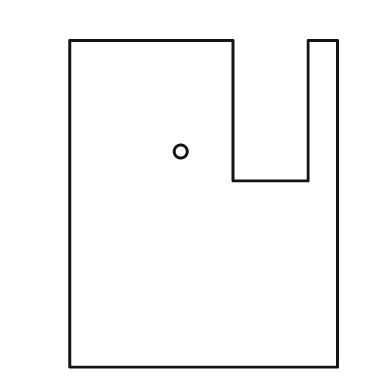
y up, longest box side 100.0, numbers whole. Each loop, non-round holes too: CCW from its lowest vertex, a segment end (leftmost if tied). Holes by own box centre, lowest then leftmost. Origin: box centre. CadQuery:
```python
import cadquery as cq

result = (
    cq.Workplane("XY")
    .moveTo(-41.0, -50.0)
    .lineTo(41.0, -50.0)
    .lineTo(41.0, 50.0)
    .lineTo(32.0, 50.0)
    .lineTo(32.0, 7.0)
    .lineTo(9.0, 7.0)
    .lineTo(9.0, 50.0)
    .lineTo(-41.0, 50.0)
    .close()
    .moveTo(-7.0, 16.0)
    .circle(2.0)
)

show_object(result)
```